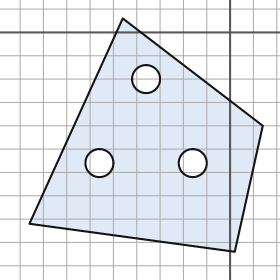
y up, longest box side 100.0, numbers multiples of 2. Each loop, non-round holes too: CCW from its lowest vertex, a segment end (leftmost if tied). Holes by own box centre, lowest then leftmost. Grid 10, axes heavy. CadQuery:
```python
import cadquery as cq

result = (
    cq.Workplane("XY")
    .moveTo(2.0, -94.0)
    .lineTo(14.0, -40.0)
    .lineTo(-46.0, 6.0)
    .lineTo(-86.0, -82.0)
    .close()
    .moveTo(-56.0, -56.0)
    .circle(6.0)
    .moveTo(-16.0, -56.0)
    .circle(6.0)
    .moveTo(-36.0, -20.0)
    .circle(6.0)
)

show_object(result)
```